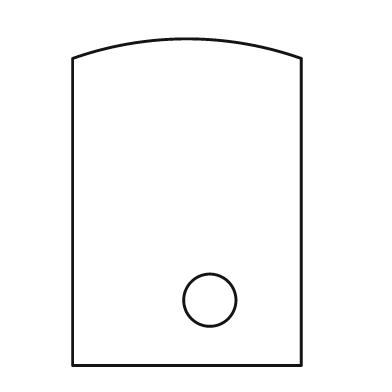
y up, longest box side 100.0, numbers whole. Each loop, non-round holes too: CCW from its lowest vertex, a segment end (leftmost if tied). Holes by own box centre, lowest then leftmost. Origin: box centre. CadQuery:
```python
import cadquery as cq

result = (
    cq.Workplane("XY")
    .moveTo(-35.0, -50.0)
    .lineTo(35.0, -50.0)
    .lineTo(35.0, 44.0)
    .threePointArc((0.0, 50.0), (-35.0, 44.0))
    .close()
    .moveTo(7.0, -30.0)
    .circle(8.0)
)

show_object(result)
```